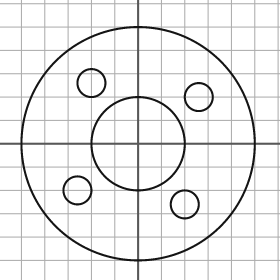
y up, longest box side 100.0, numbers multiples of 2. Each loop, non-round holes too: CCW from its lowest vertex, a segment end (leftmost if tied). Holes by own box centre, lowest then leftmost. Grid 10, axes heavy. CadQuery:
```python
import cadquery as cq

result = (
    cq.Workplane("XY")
    .moveTo(0.0, 0.0)
    .circle(50.0)
    .moveTo(20.0, -26.0)
    .circle(6.0)
    .moveTo(-26.0, -20.0)
    .circle(6.0)
    .moveTo(0.0, 0.0)
    .circle(20.0)
    .moveTo(26.0, 20.0)
    .circle(6.0)
    .moveTo(-20.0, 26.0)
    .circle(6.0)
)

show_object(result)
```